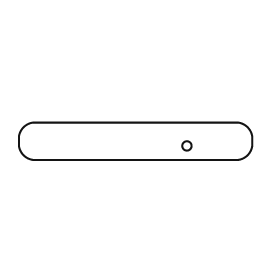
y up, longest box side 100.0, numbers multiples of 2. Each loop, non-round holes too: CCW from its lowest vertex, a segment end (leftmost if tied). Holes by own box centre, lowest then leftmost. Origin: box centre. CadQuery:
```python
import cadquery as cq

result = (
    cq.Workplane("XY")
    .moveTo(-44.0, -8.0)
    .lineTo(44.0, -8.0)
    .threePointArc((48.0, -6.0), (50.0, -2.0))
    .lineTo(50.0, 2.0)
    .threePointArc((48.0, 6.0), (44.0, 8.0))
    .lineTo(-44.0, 8.0)
    .threePointArc((-48.0, 6.0), (-50.0, 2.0))
    .lineTo(-50.0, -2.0)
    .threePointArc((-48.0, -6.0), (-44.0, -8.0))
    .close()
    .moveTo(22.0, -2.0)
    .circle(2.0)
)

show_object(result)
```